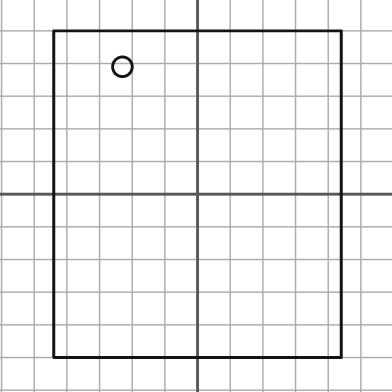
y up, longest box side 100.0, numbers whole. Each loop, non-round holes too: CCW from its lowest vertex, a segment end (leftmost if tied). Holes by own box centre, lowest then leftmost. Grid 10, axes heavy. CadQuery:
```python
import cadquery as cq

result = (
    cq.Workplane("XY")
    .moveTo(-44.0, -50.0)
    .lineTo(44.0, -50.0)
    .lineTo(44.0, 50.0)
    .lineTo(-44.0, 50.0)
    .close()
    .moveTo(-23.0, 39.0)
    .circle(3.0)
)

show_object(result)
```